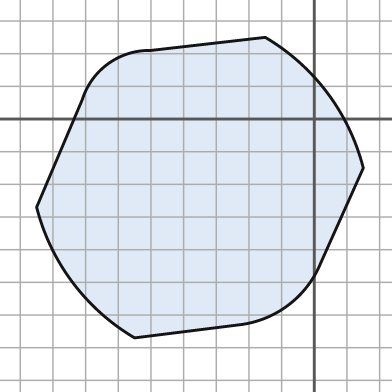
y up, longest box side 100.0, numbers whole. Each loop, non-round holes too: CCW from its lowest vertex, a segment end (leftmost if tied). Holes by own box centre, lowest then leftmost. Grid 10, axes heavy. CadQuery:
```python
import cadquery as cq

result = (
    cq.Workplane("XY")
    .moveTo(-55.0, -67.0)
    .lineTo(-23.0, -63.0)
    .threePointArc((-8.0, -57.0), (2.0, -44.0))
    .lineTo(15.0, -15.0)
    .threePointArc((4.0, 8.0), (-15.0, 25.0))
    .lineTo(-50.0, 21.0)
    .threePointArc((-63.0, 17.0), (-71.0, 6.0))
    .lineTo(-85.0, -27.0)
    .threePointArc((-74.0, -50.0), (-55.0, -67.0))
    .close()
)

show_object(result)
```